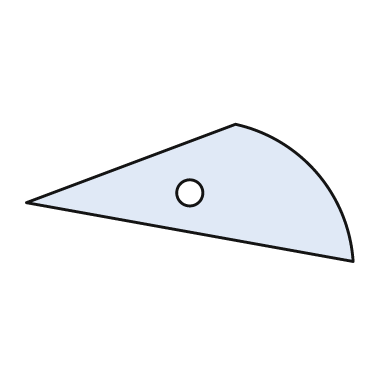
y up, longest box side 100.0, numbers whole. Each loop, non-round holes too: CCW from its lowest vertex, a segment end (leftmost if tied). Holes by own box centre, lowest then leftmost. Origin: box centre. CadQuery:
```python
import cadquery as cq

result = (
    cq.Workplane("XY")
    .moveTo(50.0, -21.0)
    .threePointArc((39.0, 6.0), (14.0, 21.0))
    .lineTo(-50.0, -3.0)
    .close()
    .moveTo(0.0, 0.0)
    .circle(4.0)
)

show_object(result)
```